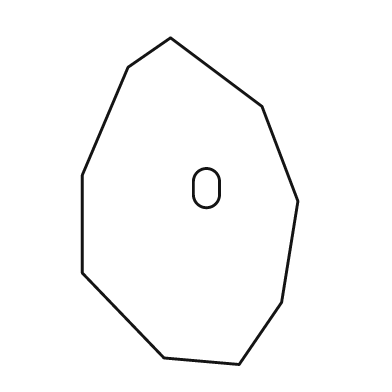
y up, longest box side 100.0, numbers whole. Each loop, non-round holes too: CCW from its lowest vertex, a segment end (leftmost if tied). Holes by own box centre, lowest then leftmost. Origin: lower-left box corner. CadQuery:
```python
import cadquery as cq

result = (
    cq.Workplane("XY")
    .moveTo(48.0, 0.0)
    .lineTo(61.0, 19.0)
    .lineTo(66.0, 50.0)
    .lineTo(55.0, 79.0)
    .lineTo(27.0, 100.0)
    .lineTo(14.0, 91.0)
    .lineTo(0.0, 58.0)
    .lineTo(0.0, 28.0)
    .lineTo(25.0, 2.0)
    .close()
    .moveTo(34.0, 52.0)
    .threePointArc((38.0, 48.0), (42.0, 52.0))
    .lineTo(42.0, 56.0)
    .threePointArc((38.0, 60.0), (34.0, 56.0))
    .close()
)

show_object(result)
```